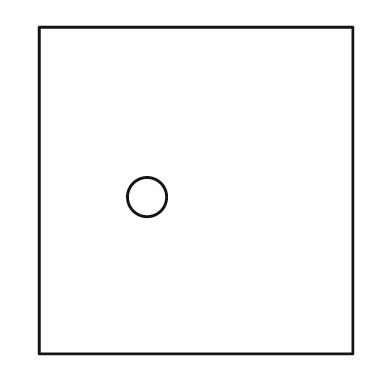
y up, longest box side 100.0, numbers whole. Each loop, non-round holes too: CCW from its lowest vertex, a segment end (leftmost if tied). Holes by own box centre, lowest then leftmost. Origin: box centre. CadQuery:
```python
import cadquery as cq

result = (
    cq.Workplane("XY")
    .moveTo(-48.0, -50.0)
    .lineTo(48.0, -50.0)
    .lineTo(48.0, 50.0)
    .lineTo(-48.0, 50.0)
    .close()
    .moveTo(-15.0, -2.0)
    .circle(6.0)
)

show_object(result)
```